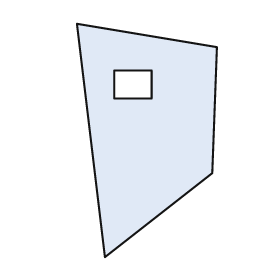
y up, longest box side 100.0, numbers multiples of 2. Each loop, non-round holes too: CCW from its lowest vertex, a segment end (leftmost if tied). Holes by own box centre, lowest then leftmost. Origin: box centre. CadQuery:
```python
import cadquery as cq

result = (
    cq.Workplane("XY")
    .moveTo(-18.0, -50.0)
    .lineTo(28.0, -14.0)
    .lineTo(30.0, 40.0)
    .lineTo(-30.0, 50.0)
    .close()
    .moveTo(-14.0, 18.0)
    .lineTo(2.0, 18.0)
    .lineTo(2.0, 30.0)
    .lineTo(-14.0, 30.0)
    .close()
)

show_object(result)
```